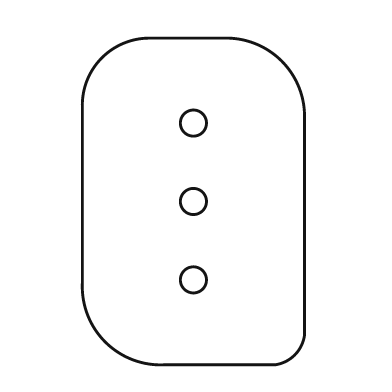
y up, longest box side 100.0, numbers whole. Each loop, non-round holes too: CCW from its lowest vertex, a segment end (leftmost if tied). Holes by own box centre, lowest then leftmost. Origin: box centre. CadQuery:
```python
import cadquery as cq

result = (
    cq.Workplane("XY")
    .moveTo(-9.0, -50.0)
    .lineTo(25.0, -50.0)
    .threePointArc((31.0, -47.0), (34.0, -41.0))
    .lineTo(34.0, 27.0)
    .threePointArc((27.0, 43.0), (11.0, 50.0))
    .lineTo(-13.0, 50.0)
    .threePointArc((-28.0, 44.0), (-34.0, 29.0))
    .lineTo(-34.0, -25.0)
    .threePointArc((-27.0, -43.0), (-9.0, -50.0))
    .close()
    .moveTo(0.0, -24.0)
    .circle(4.0)
    .moveTo(0.0, 0.0)
    .circle(4.0)
    .moveTo(0.0, 24.0)
    .circle(4.0)
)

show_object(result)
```